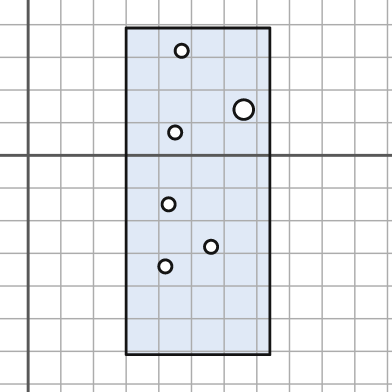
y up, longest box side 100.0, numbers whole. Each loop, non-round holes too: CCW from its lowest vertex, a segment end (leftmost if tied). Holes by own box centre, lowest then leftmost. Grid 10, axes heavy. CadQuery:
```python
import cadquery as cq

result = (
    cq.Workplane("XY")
    .moveTo(30.0, -61.0)
    .lineTo(74.0, -61.0)
    .lineTo(74.0, 39.0)
    .lineTo(30.0, 39.0)
    .close()
    .moveTo(42.0, -34.0)
    .circle(2.0)
    .moveTo(56.0, -28.0)
    .circle(2.0)
    .moveTo(43.0, -15.0)
    .circle(2.0)
    .moveTo(45.0, 7.0)
    .circle(2.0)
    .moveTo(66.0, 14.0)
    .circle(3.0)
    .moveTo(47.0, 32.0)
    .circle(2.0)
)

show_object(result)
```